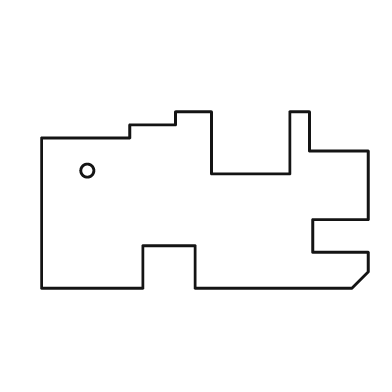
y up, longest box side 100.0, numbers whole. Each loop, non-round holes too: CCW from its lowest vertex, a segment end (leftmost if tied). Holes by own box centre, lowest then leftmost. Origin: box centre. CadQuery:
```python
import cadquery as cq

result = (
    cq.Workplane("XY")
    .moveTo(-50.0, -27.0)
    .lineTo(-19.0, -27.0)
    .lineTo(-19.0, -14.0)
    .lineTo(-3.0, -14.0)
    .lineTo(-3.0, -27.0)
    .lineTo(45.0, -27.0)
    .lineTo(50.0, -22.0)
    .lineTo(50.0, -16.0)
    .lineTo(33.0, -16.0)
    .lineTo(33.0, -6.0)
    .lineTo(50.0, -6.0)
    .lineTo(50.0, 15.0)
    .lineTo(32.0, 15.0)
    .lineTo(32.0, 27.0)
    .lineTo(26.0, 27.0)
    .lineTo(26.0, 8.0)
    .lineTo(2.0, 8.0)
    .lineTo(2.0, 27.0)
    .lineTo(-9.0, 27.0)
    .lineTo(-9.0, 23.0)
    .lineTo(-23.0, 23.0)
    .lineTo(-23.0, 19.0)
    .lineTo(-50.0, 19.0)
    .close()
    .moveTo(-36.0, 9.0)
    .circle(2.0)
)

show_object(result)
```